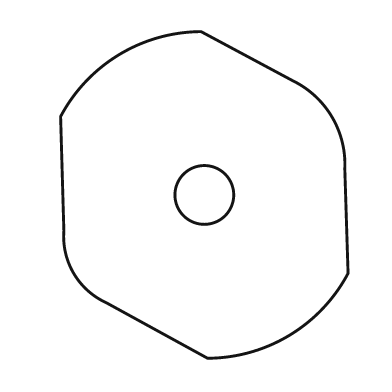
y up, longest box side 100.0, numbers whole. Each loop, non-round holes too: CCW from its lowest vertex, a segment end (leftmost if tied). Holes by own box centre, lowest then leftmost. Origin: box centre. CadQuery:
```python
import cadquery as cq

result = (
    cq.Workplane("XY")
    .moveTo(1.0, -50.0)
    .threePointArc((26.0, -43.0), (44.0, -24.0))
    .lineTo(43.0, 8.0)
    .threePointArc((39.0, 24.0), (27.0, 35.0))
    .lineTo(-1.0, 50.0)
    .threePointArc((-26.0, 43.0), (-44.0, 24.0))
    .lineTo(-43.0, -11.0)
    .threePointArc((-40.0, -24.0), (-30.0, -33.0))
    .close()
    .moveTo(0.0, 0.0)
    .circle(9.0)
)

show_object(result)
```